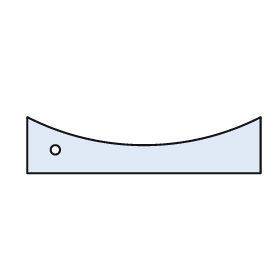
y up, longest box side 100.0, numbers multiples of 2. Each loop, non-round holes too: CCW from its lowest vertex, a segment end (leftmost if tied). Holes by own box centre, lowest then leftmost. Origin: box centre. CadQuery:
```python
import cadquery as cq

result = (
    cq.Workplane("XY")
    .moveTo(-50.0, -12.0)
    .lineTo(50.0, -12.0)
    .lineTo(50.0, 12.0)
    .threePointArc((0.0, 0.0), (-50.0, 12.0))
    .close()
    .moveTo(-38.0, -2.0)
    .circle(2.0)
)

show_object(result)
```